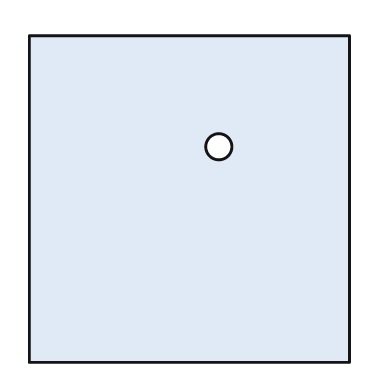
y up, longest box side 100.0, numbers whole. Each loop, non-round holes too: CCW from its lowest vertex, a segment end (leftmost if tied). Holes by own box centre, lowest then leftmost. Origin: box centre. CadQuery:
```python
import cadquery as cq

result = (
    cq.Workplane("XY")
    .moveTo(-49.0, -50.0)
    .lineTo(49.0, -50.0)
    .lineTo(49.0, 50.0)
    .lineTo(-49.0, 50.0)
    .close()
    .moveTo(9.0, 16.0)
    .circle(4.0)
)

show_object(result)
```